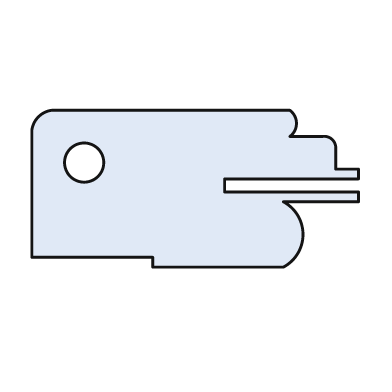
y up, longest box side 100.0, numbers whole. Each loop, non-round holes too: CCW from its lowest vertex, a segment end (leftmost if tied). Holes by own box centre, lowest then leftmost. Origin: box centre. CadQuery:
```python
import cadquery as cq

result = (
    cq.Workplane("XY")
    .moveTo(-13.0, -24.0)
    .lineTo(27.0, -24.0)
    .threePointArc((33.0, -14.0), (27.0, -4.0))
    .lineTo(50.0, -4.0)
    .lineTo(50.0, -1.0)
    .lineTo(9.0, -1.0)
    .lineTo(9.0, 3.0)
    .lineTo(50.0, 3.0)
    .lineTo(50.0, 6.0)
    .lineTo(43.0, 6.0)
    .lineTo(43.0, 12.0)
    .threePointArc((42.0, 15.0), (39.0, 16.0))
    .lineTo(29.0, 16.0)
    .threePointArc((31.0, 20.0), (29.0, 24.0))
    .lineTo(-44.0, 24.0)
    .threePointArc((-48.0, 22.0), (-50.0, 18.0))
    .lineTo(-50.0, -21.0)
    .lineTo(-13.0, -21.0)
    .close()
    .moveTo(-34.0, 8.0)
    .circle(6.0)
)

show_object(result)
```